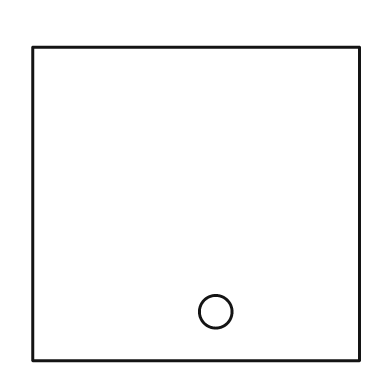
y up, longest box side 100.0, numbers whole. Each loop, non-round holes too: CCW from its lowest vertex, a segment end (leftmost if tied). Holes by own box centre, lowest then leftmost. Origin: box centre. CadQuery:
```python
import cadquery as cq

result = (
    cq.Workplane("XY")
    .moveTo(-50.0, -48.0)
    .lineTo(50.0, -48.0)
    .lineTo(50.0, 48.0)
    .lineTo(-50.0, 48.0)
    .close()
    .moveTo(6.0, -33.0)
    .circle(5.0)
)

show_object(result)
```